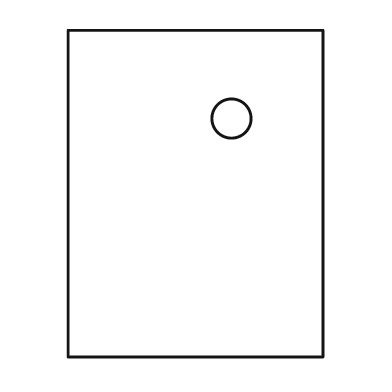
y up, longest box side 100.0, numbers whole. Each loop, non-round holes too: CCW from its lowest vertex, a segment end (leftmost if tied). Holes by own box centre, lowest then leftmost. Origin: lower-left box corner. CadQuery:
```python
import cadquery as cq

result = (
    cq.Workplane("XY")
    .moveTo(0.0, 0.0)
    .lineTo(78.0, 0.0)
    .lineTo(78.0, 100.0)
    .lineTo(0.0, 100.0)
    .close()
    .moveTo(50.0, 73.0)
    .circle(6.0)
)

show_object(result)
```